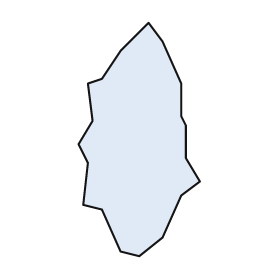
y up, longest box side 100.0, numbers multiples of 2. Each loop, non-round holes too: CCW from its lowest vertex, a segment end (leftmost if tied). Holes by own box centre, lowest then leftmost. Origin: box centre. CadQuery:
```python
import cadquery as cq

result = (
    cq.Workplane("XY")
    .moveTo(0.0, -50.0)
    .lineTo(10.0, -42.0)
    .lineTo(18.0, -24.0)
    .lineTo(26.0, -18.0)
    .lineTo(20.0, -8.0)
    .lineTo(20.0, 6.0)
    .lineTo(18.0, 10.0)
    .lineTo(18.0, 24.0)
    .lineTo(10.0, 42.0)
    .lineTo(4.0, 50.0)
    .lineTo(-8.0, 38.0)
    .lineTo(-16.0, 26.0)
    .lineTo(-22.0, 24.0)
    .lineTo(-20.0, 8.0)
    .lineTo(-26.0, -2.0)
    .lineTo(-22.0, -10.0)
    .lineTo(-24.0, -28.0)
    .lineTo(-16.0, -30.0)
    .lineTo(-8.0, -48.0)
    .close()
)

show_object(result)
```